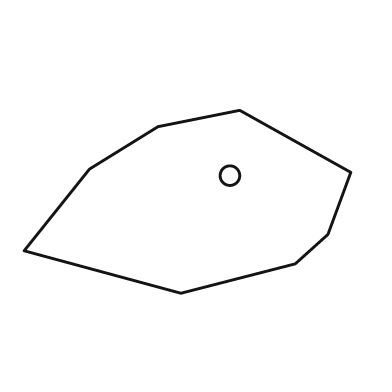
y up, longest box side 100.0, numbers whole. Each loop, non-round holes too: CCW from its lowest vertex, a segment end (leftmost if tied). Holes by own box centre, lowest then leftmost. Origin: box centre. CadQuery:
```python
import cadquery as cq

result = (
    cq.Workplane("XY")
    .moveTo(-2.0, -28.0)
    .lineTo(33.0, -19.0)
    .lineTo(43.0, -10.0)
    .lineTo(50.0, 9.0)
    .lineTo(16.0, 28.0)
    .lineTo(-9.0, 23.0)
    .lineTo(-30.0, 10.0)
    .lineTo(-50.0, -15.0)
    .close()
    .moveTo(13.0, 8.0)
    .circle(3.0)
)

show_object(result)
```